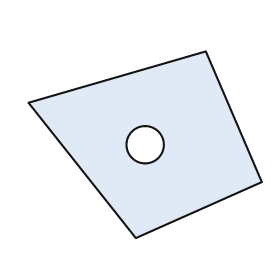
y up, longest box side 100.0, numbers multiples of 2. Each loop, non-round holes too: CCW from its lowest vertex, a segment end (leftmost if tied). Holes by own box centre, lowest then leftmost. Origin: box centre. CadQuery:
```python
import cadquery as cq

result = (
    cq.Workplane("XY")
    .moveTo(-4.0, -40.0)
    .lineTo(50.0, -16.0)
    .lineTo(26.0, 40.0)
    .lineTo(-50.0, 18.0)
    .close()
    .moveTo(0.0, 0.0)
    .circle(8.0)
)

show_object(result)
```